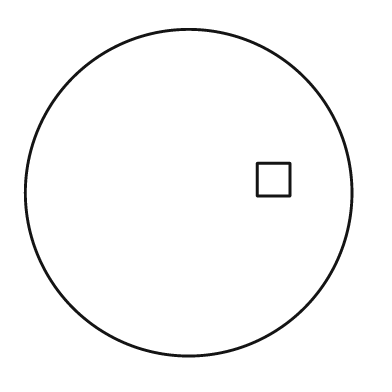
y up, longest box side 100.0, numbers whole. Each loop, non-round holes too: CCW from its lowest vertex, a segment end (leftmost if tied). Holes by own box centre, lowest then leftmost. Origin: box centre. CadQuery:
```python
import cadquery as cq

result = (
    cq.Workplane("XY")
    .moveTo(0.0, 0.0)
    .circle(50.0)
    .moveTo(21.0, -1.0)
    .lineTo(31.0, -1.0)
    .lineTo(31.0, 9.0)
    .lineTo(21.0, 9.0)
    .close()
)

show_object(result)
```